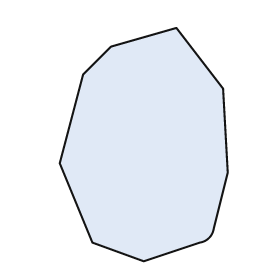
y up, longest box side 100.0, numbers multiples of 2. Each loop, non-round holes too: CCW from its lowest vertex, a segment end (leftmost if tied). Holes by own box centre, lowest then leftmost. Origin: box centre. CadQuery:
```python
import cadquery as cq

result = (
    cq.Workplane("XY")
    .moveTo(0.0, -50.0)
    .lineTo(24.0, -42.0)
    .threePointArc((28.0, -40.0), (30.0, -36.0))
    .lineTo(36.0, -12.0)
    .lineTo(34.0, 24.0)
    .lineTo(14.0, 50.0)
    .lineTo(-14.0, 42.0)
    .lineTo(-26.0, 30.0)
    .lineTo(-36.0, -8.0)
    .lineTo(-22.0, -42.0)
    .close()
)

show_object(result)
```